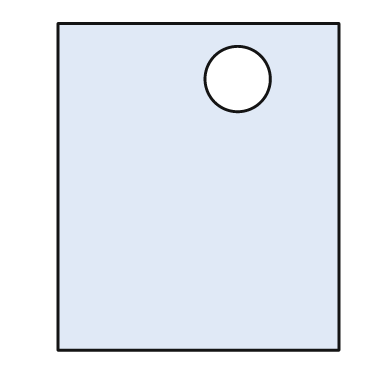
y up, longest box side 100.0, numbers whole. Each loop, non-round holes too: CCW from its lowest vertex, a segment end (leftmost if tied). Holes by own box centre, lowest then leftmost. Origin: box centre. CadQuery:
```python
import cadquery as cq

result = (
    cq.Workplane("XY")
    .moveTo(-43.0, -50.0)
    .lineTo(43.0, -50.0)
    .lineTo(43.0, 50.0)
    .lineTo(-43.0, 50.0)
    .close()
    .moveTo(12.0, 33.0)
    .circle(10.0)
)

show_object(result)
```